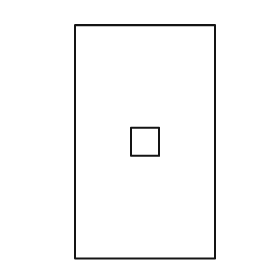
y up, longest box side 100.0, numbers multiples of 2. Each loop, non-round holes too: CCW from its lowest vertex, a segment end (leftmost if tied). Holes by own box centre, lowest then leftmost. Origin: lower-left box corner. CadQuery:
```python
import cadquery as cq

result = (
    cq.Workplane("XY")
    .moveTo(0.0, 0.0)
    .lineTo(60.0, 0.0)
    .lineTo(60.0, 100.0)
    .lineTo(0.0, 100.0)
    .close()
    .moveTo(24.0, 44.0)
    .lineTo(36.0, 44.0)
    .lineTo(36.0, 56.0)
    .lineTo(24.0, 56.0)
    .close()
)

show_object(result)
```